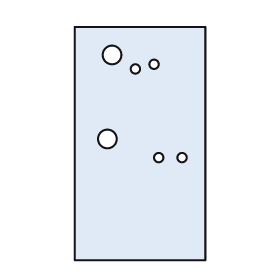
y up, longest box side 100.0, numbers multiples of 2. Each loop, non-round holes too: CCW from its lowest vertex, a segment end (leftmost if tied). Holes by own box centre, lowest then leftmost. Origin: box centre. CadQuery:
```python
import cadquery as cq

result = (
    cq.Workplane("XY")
    .moveTo(-28.0, -50.0)
    .lineTo(28.0, -50.0)
    .lineTo(28.0, 50.0)
    .lineTo(-28.0, 50.0)
    .close()
    .moveTo(8.0, -6.0)
    .circle(2.0)
    .moveTo(18.0, -6.0)
    .circle(2.0)
    .moveTo(-14.0, 2.0)
    .circle(4.0)
    .moveTo(-2.0, 32.0)
    .circle(2.0)
    .moveTo(6.0, 34.0)
    .circle(2.0)
    .moveTo(-12.0, 38.0)
    .circle(4.0)
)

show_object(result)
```